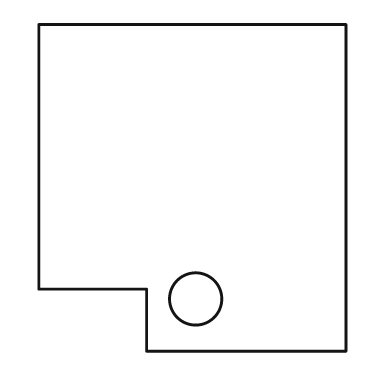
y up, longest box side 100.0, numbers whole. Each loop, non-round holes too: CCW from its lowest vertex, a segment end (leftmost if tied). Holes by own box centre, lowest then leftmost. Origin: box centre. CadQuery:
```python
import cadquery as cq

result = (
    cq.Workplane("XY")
    .moveTo(-14.0, -50.0)
    .lineTo(47.0, -50.0)
    .lineTo(47.0, 50.0)
    .lineTo(-47.0, 50.0)
    .lineTo(-47.0, -31.0)
    .lineTo(-14.0, -31.0)
    .close()
    .moveTo(1.0, -34.0)
    .circle(8.0)
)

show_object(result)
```